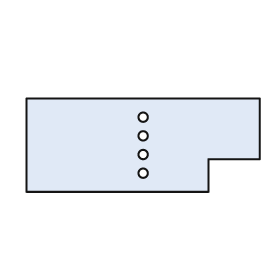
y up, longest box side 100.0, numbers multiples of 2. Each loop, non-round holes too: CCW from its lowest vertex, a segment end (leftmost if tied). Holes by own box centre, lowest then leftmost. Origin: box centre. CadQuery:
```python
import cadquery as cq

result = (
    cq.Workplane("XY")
    .moveTo(-50.0, -20.0)
    .lineTo(28.0, -20.0)
    .lineTo(28.0, -6.0)
    .lineTo(50.0, -6.0)
    .lineTo(50.0, 20.0)
    .lineTo(-50.0, 20.0)
    .close()
    .moveTo(0.0, -12.0)
    .circle(2.0)
    .moveTo(0.0, -4.0)
    .circle(2.0)
    .moveTo(0.0, 4.0)
    .circle(2.0)
    .moveTo(0.0, 12.0)
    .circle(2.0)
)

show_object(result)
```